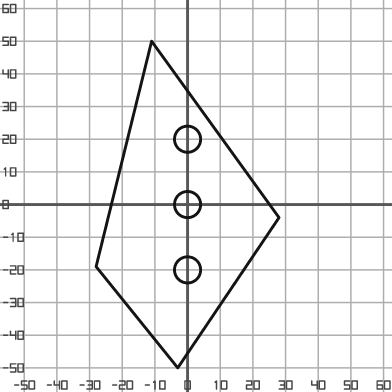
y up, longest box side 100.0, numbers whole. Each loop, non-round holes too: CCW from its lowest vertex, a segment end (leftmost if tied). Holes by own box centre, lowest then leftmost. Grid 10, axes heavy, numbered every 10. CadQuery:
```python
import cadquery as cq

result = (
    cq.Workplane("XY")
    .moveTo(-3.0, -50.0)
    .lineTo(28.0, -4.0)
    .lineTo(-11.0, 50.0)
    .lineTo(-28.0, -19.0)
    .close()
    .moveTo(0.0, -20.0)
    .circle(4.0)
    .moveTo(0.0, 0.0)
    .circle(4.0)
    .moveTo(0.0, 20.0)
    .circle(4.0)
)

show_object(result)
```